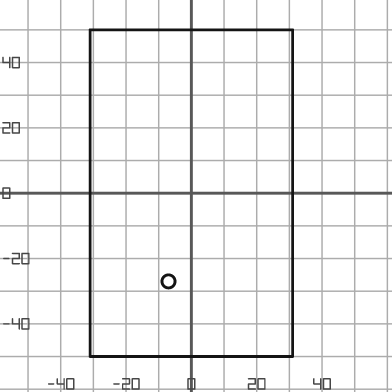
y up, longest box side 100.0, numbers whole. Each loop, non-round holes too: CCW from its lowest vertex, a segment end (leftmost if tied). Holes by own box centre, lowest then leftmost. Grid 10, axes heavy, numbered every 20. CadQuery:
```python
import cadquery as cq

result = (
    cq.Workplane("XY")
    .moveTo(-31.0, -50.0)
    .lineTo(31.0, -50.0)
    .lineTo(31.0, 50.0)
    .lineTo(-31.0, 50.0)
    .close()
    .moveTo(-7.0, -27.0)
    .circle(2.0)
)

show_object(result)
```